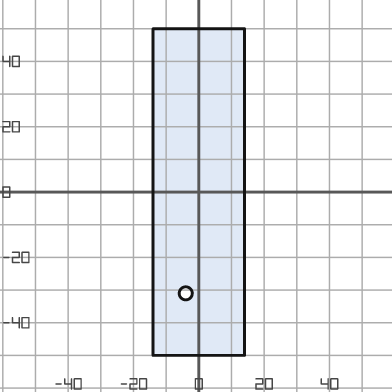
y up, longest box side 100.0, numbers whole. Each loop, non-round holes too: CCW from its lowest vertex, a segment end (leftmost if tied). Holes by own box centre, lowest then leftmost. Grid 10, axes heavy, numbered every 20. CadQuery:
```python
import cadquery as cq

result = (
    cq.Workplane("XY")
    .moveTo(-14.0, -50.0)
    .lineTo(14.0, -50.0)
    .lineTo(14.0, 50.0)
    .lineTo(-14.0, 50.0)
    .close()
    .moveTo(-4.0, -31.0)
    .circle(2.0)
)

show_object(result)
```